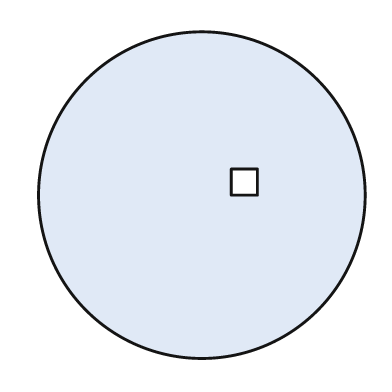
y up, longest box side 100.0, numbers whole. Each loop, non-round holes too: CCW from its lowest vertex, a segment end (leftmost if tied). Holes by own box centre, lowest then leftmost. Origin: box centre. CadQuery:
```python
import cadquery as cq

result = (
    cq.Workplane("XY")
    .moveTo(0.0, 0.0)
    .circle(50.0)
    .moveTo(9.0, 0.0)
    .lineTo(17.0, 0.0)
    .lineTo(17.0, 8.0)
    .lineTo(9.0, 8.0)
    .close()
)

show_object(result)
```